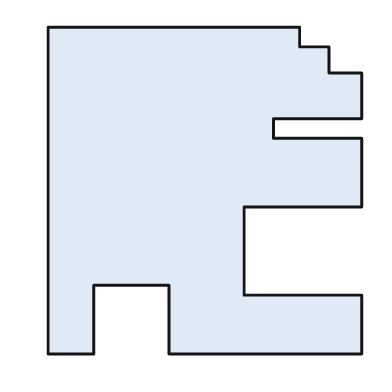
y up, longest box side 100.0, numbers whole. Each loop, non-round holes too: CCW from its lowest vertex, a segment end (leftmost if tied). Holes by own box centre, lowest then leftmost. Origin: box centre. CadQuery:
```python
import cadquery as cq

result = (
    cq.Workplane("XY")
    .moveTo(-48.0, -50.0)
    .lineTo(-34.0, -50.0)
    .lineTo(-34.0, -29.0)
    .lineTo(-11.0, -29.0)
    .lineTo(-11.0, -50.0)
    .lineTo(48.0, -50.0)
    .lineTo(48.0, -32.0)
    .lineTo(12.0, -32.0)
    .lineTo(12.0, -5.0)
    .lineTo(48.0, -5.0)
    .lineTo(48.0, 16.0)
    .lineTo(21.0, 16.0)
    .lineTo(21.0, 22.0)
    .lineTo(48.0, 22.0)
    .lineTo(48.0, 36.0)
    .lineTo(38.0, 36.0)
    .lineTo(38.0, 44.0)
    .lineTo(29.0, 44.0)
    .lineTo(29.0, 50.0)
    .lineTo(-48.0, 50.0)
    .close()
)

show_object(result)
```